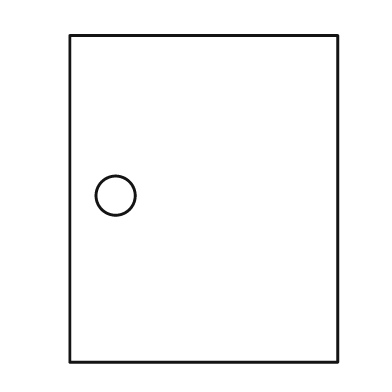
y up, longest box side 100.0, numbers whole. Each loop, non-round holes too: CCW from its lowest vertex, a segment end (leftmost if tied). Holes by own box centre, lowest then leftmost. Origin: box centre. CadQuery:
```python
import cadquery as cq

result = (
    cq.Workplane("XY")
    .moveTo(-41.0, -50.0)
    .lineTo(41.0, -50.0)
    .lineTo(41.0, 50.0)
    .lineTo(-41.0, 50.0)
    .close()
    .moveTo(-27.0, 1.0)
    .circle(6.0)
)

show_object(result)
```